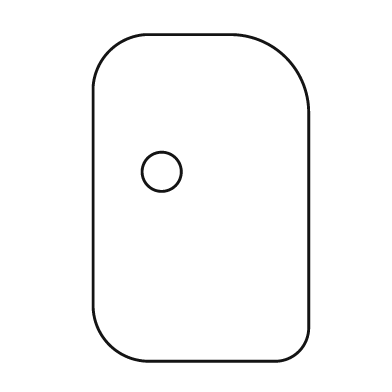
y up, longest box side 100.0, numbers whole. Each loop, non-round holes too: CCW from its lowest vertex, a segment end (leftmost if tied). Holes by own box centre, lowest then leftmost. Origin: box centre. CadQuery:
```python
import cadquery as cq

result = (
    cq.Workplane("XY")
    .moveTo(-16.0, -50.0)
    .lineTo(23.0, -50.0)
    .threePointArc((30.0, -47.0), (33.0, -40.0))
    .lineTo(33.0, 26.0)
    .threePointArc((26.0, 43.0), (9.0, 50.0))
    .lineTo(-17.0, 50.0)
    .threePointArc((-28.0, 45.0), (-33.0, 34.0))
    .lineTo(-33.0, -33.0)
    .threePointArc((-28.0, -45.0), (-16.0, -50.0))
    .close()
    .moveTo(-12.0, 8.0)
    .circle(6.0)
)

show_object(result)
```